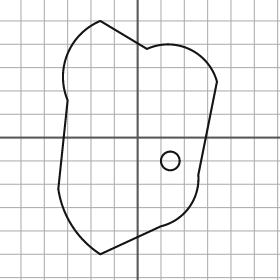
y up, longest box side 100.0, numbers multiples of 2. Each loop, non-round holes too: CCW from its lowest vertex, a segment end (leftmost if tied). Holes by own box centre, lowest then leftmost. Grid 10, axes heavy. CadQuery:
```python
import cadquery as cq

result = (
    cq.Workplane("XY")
    .moveTo(-16.0, -50.0)
    .lineTo(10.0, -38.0)
    .threePointArc((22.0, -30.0), (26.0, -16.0))
    .lineTo(34.0, 24.0)
    .threePointArc((22.0, 38.0), (4.0, 38.0))
    .lineTo(-16.0, 50.0)
    .threePointArc((-30.0, 36.0), (-30.0, 16.0))
    .lineTo(-34.0, -22.0)
    .threePointArc((-28.0, -38.0), (-16.0, -50.0))
    .close()
    .moveTo(14.0, -10.0)
    .circle(4.0)
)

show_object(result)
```